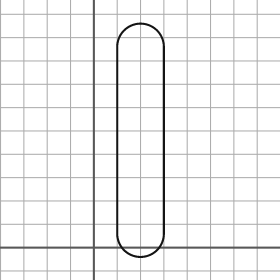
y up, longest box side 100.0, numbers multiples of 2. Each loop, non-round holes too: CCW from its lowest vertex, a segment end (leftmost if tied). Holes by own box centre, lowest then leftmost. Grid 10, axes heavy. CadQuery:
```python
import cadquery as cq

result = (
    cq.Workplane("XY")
    .moveTo(10.0, 6.0)
    .threePointArc((20.0, -4.0), (30.0, 6.0))
    .lineTo(30.0, 86.0)
    .threePointArc((20.0, 96.0), (10.0, 86.0))
    .close()
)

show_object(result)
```